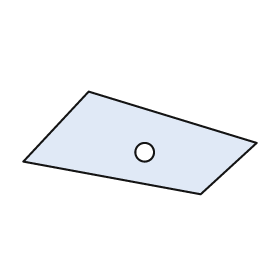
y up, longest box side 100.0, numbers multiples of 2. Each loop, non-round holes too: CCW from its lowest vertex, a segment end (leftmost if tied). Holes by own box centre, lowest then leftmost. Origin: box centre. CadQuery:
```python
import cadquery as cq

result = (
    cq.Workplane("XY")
    .moveTo(26.0, -22.0)
    .lineTo(50.0, 0.0)
    .lineTo(-22.0, 22.0)
    .lineTo(-50.0, -8.0)
    .close()
    .moveTo(2.0, -4.0)
    .circle(4.0)
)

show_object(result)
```